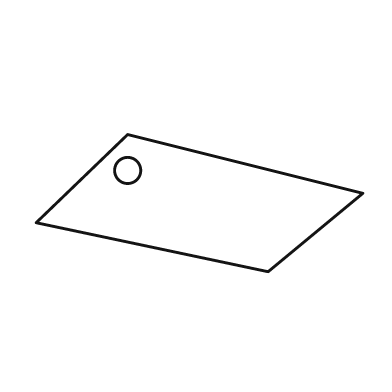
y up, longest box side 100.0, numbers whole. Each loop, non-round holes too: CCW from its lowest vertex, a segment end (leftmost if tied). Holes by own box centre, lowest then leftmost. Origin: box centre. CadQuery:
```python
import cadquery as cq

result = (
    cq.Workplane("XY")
    .moveTo(21.0, -21.0)
    .lineTo(50.0, 3.0)
    .lineTo(-22.0, 21.0)
    .lineTo(-50.0, -6.0)
    .close()
    .moveTo(-22.0, 10.0)
    .circle(4.0)
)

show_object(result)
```